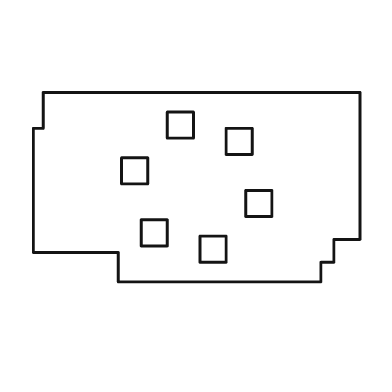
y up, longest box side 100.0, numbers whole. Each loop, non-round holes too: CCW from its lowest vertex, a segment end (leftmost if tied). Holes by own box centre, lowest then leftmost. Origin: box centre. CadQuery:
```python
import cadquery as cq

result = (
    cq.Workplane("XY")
    .moveTo(-24.0, -29.0)
    .lineTo(38.0, -29.0)
    .lineTo(38.0, -23.0)
    .lineTo(42.0, -23.0)
    .lineTo(42.0, -16.0)
    .lineTo(50.0, -16.0)
    .lineTo(50.0, 29.0)
    .lineTo(-47.0, 29.0)
    .lineTo(-47.0, 18.0)
    .lineTo(-50.0, 18.0)
    .lineTo(-50.0, -20.0)
    .lineTo(-24.0, -20.0)
    .close()
    .moveTo(1.0, -23.0)
    .lineTo(9.0, -23.0)
    .lineTo(9.0, -15.0)
    .lineTo(1.0, -15.0)
    .close()
    .moveTo(-17.0, -18.0)
    .lineTo(-9.0, -18.0)
    .lineTo(-9.0, -10.0)
    .lineTo(-17.0, -10.0)
    .close()
    .moveTo(15.0, -9.0)
    .lineTo(23.0, -9.0)
    .lineTo(23.0, -1.0)
    .lineTo(15.0, -1.0)
    .close()
    .moveTo(-23.0, 1.0)
    .lineTo(-15.0, 1.0)
    .lineTo(-15.0, 9.0)
    .lineTo(-23.0, 9.0)
    .close()
    .moveTo(9.0, 10.0)
    .lineTo(17.0, 10.0)
    .lineTo(17.0, 18.0)
    .lineTo(9.0, 18.0)
    .close()
    .moveTo(-9.0, 15.0)
    .lineTo(-1.0, 15.0)
    .lineTo(-1.0, 23.0)
    .lineTo(-9.0, 23.0)
    .close()
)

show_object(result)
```